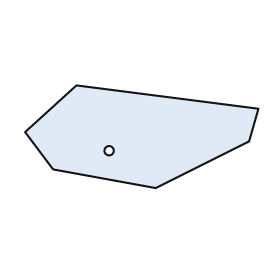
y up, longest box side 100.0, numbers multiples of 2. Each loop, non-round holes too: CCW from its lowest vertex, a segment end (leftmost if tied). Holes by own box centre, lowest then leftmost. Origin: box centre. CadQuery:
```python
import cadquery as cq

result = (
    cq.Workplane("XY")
    .moveTo(6.0, -22.0)
    .lineTo(46.0, -2.0)
    .lineTo(50.0, 12.0)
    .lineTo(-28.0, 22.0)
    .lineTo(-50.0, 2.0)
    .lineTo(-38.0, -14.0)
    .close()
    .moveTo(-14.0, -6.0)
    .circle(2.0)
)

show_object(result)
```